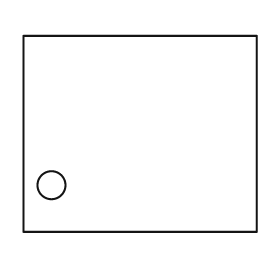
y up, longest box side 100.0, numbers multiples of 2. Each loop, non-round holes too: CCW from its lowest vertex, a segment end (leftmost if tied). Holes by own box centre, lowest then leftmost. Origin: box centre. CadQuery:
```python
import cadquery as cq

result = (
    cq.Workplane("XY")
    .moveTo(-50.0, -42.0)
    .lineTo(50.0, -42.0)
    .lineTo(50.0, 42.0)
    .lineTo(-50.0, 42.0)
    .close()
    .moveTo(-38.0, -22.0)
    .circle(6.0)
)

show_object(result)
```